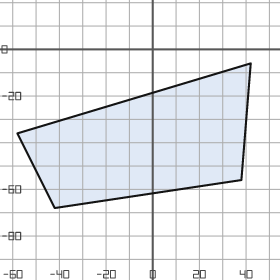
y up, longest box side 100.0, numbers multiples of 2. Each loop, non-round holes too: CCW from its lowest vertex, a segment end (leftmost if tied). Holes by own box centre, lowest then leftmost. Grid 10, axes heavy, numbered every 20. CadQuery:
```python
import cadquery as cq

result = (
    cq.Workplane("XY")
    .moveTo(-42.0, -68.0)
    .lineTo(38.0, -56.0)
    .lineTo(42.0, -6.0)
    .lineTo(-58.0, -36.0)
    .close()
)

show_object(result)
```